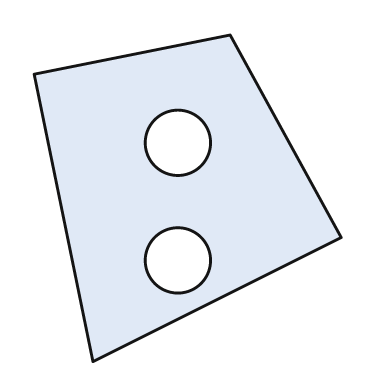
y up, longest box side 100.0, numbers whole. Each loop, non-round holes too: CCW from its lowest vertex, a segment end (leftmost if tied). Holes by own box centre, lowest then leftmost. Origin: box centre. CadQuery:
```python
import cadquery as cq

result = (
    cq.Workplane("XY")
    .moveTo(-29.0, -50.0)
    .lineTo(47.0, -12.0)
    .lineTo(13.0, 50.0)
    .lineTo(-47.0, 38.0)
    .close()
    .moveTo(-3.0, -19.0)
    .circle(10.0)
    .moveTo(-3.0, 17.0)
    .circle(10.0)
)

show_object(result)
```